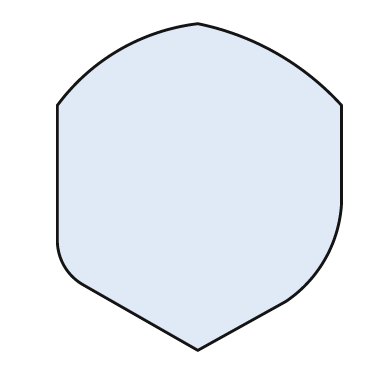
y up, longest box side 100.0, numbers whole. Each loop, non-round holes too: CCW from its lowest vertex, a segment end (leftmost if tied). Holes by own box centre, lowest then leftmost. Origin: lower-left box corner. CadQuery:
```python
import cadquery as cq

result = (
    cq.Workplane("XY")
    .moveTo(43.0, 0.0)
    .lineTo(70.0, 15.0)
    .threePointArc((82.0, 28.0), (87.0, 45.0))
    .lineTo(87.0, 75.0)
    .threePointArc((67.0, 91.0), (43.0, 100.0))
    .threePointArc((19.0, 92.0), (0.0, 75.0))
    .lineTo(0.0, 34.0)
    .threePointArc((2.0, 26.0), (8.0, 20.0))
    .close()
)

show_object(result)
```